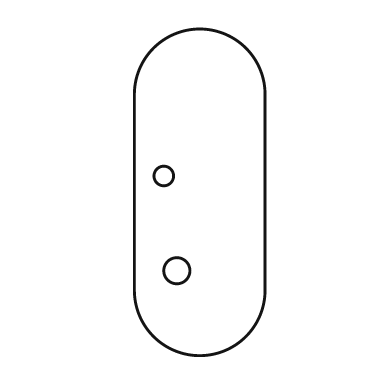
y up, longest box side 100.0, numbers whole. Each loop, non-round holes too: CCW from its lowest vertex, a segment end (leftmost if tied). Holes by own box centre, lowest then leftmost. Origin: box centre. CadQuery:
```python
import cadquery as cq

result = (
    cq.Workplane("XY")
    .moveTo(-20.0, -30.0)
    .threePointArc((0.0, -50.0), (20.0, -30.0))
    .lineTo(20.0, 30.0)
    .threePointArc((0.0, 50.0), (-20.0, 30.0))
    .close()
    .moveTo(-7.0, -24.0)
    .circle(4.0)
    .moveTo(-11.0, 5.0)
    .circle(3.0)
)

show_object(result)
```